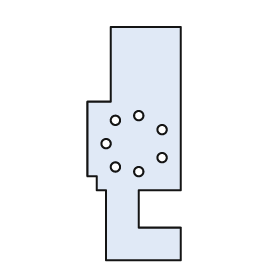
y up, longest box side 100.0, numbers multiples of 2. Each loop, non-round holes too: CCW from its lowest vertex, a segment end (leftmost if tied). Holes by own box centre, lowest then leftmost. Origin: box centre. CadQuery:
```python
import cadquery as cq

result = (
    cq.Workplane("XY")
    .moveTo(-12.0, -50.0)
    .lineTo(20.0, -50.0)
    .lineTo(20.0, -36.0)
    .lineTo(2.0, -36.0)
    .lineTo(2.0, -20.0)
    .lineTo(20.0, -20.0)
    .lineTo(20.0, 50.0)
    .lineTo(-10.0, 50.0)
    .lineTo(-10.0, 18.0)
    .lineTo(-20.0, 18.0)
    .lineTo(-20.0, -14.0)
    .lineTo(-16.0, -14.0)
    .lineTo(-16.0, -20.0)
    .lineTo(-12.0, -20.0)
    .close()
    .moveTo(2.0, -12.0)
    .circle(2.0)
    .moveTo(-8.0, -10.0)
    .circle(2.0)
    .moveTo(12.0, -6.0)
    .circle(2.0)
    .moveTo(-12.0, 0.0)
    .circle(2.0)
    .moveTo(12.0, 6.0)
    .circle(2.0)
    .moveTo(-8.0, 10.0)
    .circle(2.0)
    .moveTo(2.0, 12.0)
    .circle(2.0)
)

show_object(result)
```